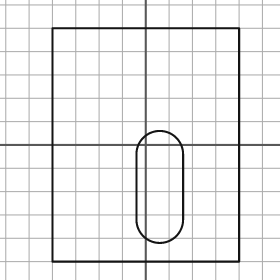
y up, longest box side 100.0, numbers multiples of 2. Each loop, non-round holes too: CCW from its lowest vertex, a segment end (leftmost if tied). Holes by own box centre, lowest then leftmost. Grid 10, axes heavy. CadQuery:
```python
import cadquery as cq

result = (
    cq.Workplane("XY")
    .moveTo(-40.0, -50.0)
    .lineTo(40.0, -50.0)
    .lineTo(40.0, 50.0)
    .lineTo(-40.0, 50.0)
    .close()
    .moveTo(-4.0, -32.0)
    .threePointArc((6.0, -42.0), (16.0, -32.0))
    .lineTo(16.0, -4.0)
    .threePointArc((6.0, 6.0), (-4.0, -4.0))
    .close()
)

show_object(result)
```